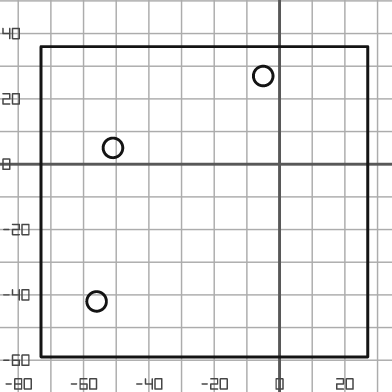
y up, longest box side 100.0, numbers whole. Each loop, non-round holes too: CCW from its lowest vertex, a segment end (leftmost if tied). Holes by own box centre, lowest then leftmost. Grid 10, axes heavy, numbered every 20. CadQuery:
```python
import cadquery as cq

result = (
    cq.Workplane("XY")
    .moveTo(-73.0, -59.0)
    .lineTo(27.0, -59.0)
    .lineTo(27.0, 36.0)
    .lineTo(-73.0, 36.0)
    .close()
    .moveTo(-56.0, -42.0)
    .circle(3.0)
    .moveTo(-51.0, 5.0)
    .circle(3.0)
    .moveTo(-5.0, 27.0)
    .circle(3.0)
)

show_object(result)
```